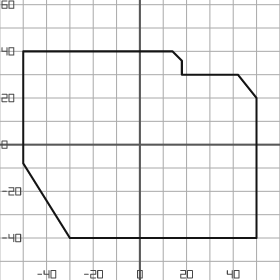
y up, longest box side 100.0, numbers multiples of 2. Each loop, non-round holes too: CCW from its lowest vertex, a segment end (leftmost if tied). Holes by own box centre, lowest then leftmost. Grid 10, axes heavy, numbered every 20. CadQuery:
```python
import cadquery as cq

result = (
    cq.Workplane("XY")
    .moveTo(-30.0, -40.0)
    .lineTo(50.0, -40.0)
    .lineTo(50.0, 20.0)
    .lineTo(42.0, 30.0)
    .lineTo(18.0, 30.0)
    .lineTo(18.0, 36.0)
    .lineTo(14.0, 40.0)
    .lineTo(-50.0, 40.0)
    .lineTo(-50.0, -8.0)
    .close()
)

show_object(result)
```